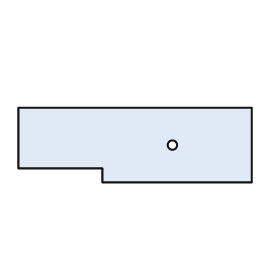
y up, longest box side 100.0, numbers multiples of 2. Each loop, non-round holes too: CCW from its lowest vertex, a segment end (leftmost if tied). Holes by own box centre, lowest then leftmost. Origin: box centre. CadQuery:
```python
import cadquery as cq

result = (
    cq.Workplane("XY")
    .moveTo(-14.0, -16.0)
    .lineTo(50.0, -16.0)
    .lineTo(50.0, 16.0)
    .lineTo(-50.0, 16.0)
    .lineTo(-50.0, -10.0)
    .lineTo(-14.0, -10.0)
    .close()
    .moveTo(16.0, 0.0)
    .circle(2.0)
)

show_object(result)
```